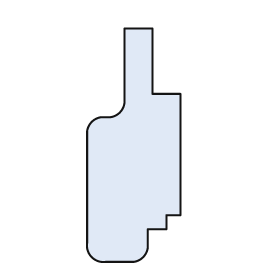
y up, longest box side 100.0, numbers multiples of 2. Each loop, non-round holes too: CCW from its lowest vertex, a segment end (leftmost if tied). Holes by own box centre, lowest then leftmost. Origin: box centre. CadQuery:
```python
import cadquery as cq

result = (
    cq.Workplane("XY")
    .moveTo(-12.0, -50.0)
    .lineTo(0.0, -50.0)
    .threePointArc((4.0, -48.0), (6.0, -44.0))
    .lineTo(6.0, -36.0)
    .lineTo(14.0, -36.0)
    .lineTo(14.0, -30.0)
    .lineTo(20.0, -30.0)
    .lineTo(20.0, 22.0)
    .lineTo(8.0, 22.0)
    .lineTo(8.0, 50.0)
    .lineTo(-4.0, 50.0)
    .lineTo(-4.0, 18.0)
    .threePointArc((-6.0, 14.0), (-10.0, 12.0))
    .lineTo(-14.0, 12.0)
    .threePointArc((-18.0, 10.0), (-20.0, 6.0))
    .lineTo(-20.0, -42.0)
    .threePointArc((-18.0, -48.0), (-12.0, -50.0))
    .close()
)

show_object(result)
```